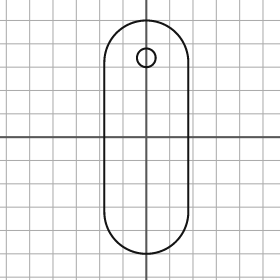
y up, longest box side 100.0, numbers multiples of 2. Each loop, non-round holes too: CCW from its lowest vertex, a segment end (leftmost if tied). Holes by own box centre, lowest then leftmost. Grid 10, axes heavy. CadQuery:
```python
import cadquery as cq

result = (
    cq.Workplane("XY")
    .moveTo(-18.0, -32.0)
    .threePointArc((0.0, -50.0), (18.0, -32.0))
    .lineTo(18.0, 32.0)
    .threePointArc((0.0, 50.0), (-18.0, 32.0))
    .close()
    .moveTo(0.0, 34.0)
    .circle(4.0)
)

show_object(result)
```